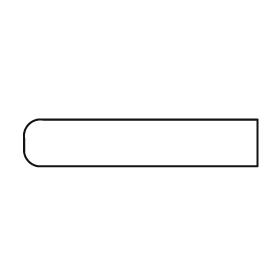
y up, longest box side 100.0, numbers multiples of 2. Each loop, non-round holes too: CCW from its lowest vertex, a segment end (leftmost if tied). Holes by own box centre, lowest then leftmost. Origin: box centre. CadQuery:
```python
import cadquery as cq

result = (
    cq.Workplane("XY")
    .moveTo(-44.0, -10.0)
    .lineTo(50.0, -10.0)
    .lineTo(50.0, 10.0)
    .lineTo(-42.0, 10.0)
    .threePointArc((-48.0, 8.0), (-50.0, 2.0))
    .lineTo(-50.0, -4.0)
    .threePointArc((-48.0, -8.0), (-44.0, -10.0))
    .close()
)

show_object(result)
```